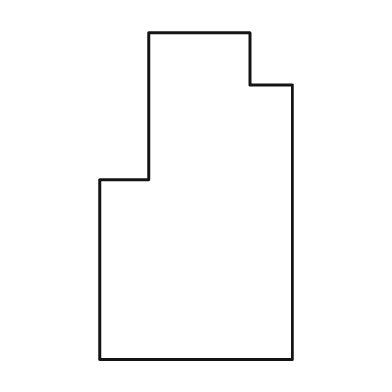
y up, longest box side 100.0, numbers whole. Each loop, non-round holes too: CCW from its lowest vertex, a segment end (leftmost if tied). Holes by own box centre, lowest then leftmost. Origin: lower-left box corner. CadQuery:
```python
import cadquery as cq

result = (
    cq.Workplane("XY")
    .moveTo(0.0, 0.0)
    .lineTo(59.0, 0.0)
    .lineTo(59.0, 84.0)
    .lineTo(46.0, 84.0)
    .lineTo(46.0, 100.0)
    .lineTo(15.0, 100.0)
    .lineTo(15.0, 55.0)
    .lineTo(0.0, 55.0)
    .close()
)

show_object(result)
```